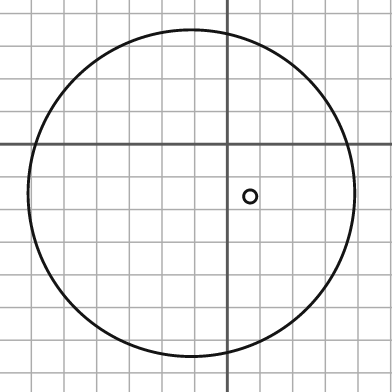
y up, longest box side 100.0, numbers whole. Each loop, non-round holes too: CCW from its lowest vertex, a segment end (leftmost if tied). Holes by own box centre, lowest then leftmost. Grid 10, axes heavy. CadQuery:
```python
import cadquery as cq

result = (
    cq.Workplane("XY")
    .moveTo(-11.0, -15.0)
    .circle(50.0)
    .moveTo(7.0, -16.0)
    .circle(2.0)
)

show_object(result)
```